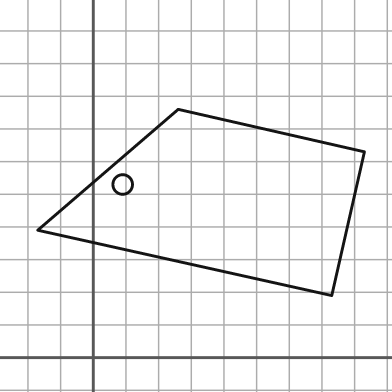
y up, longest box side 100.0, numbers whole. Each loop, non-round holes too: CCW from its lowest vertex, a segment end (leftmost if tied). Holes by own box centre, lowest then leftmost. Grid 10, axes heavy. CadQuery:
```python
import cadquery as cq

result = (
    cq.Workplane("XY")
    .moveTo(73.0, 19.0)
    .lineTo(83.0, 63.0)
    .lineTo(26.0, 76.0)
    .lineTo(-17.0, 39.0)
    .close()
    .moveTo(9.0, 53.0)
    .circle(3.0)
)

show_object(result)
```